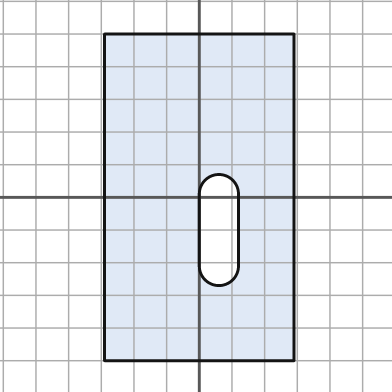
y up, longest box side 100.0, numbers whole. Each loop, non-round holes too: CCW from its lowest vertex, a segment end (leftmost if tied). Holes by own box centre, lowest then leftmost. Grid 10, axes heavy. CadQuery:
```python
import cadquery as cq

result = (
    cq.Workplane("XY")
    .moveTo(-29.0, -50.0)
    .lineTo(29.0, -50.0)
    .lineTo(29.0, 50.0)
    .lineTo(-29.0, 50.0)
    .close()
    .moveTo(0.0, -21.0)
    .threePointArc((6.0, -27.0), (12.0, -21.0))
    .lineTo(12.0, 1.0)
    .threePointArc((6.0, 7.0), (0.0, 1.0))
    .close()
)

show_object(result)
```